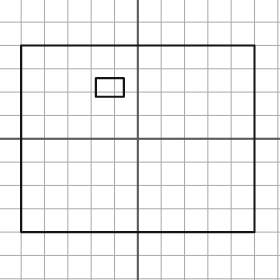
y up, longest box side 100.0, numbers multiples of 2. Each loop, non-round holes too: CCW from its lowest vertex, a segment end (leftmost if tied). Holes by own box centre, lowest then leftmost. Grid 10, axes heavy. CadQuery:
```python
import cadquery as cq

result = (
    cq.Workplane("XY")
    .moveTo(-50.0, -40.0)
    .lineTo(50.0, -40.0)
    .lineTo(50.0, 40.0)
    .lineTo(-50.0, 40.0)
    .close()
    .moveTo(-18.0, 18.0)
    .lineTo(-6.0, 18.0)
    .lineTo(-6.0, 26.0)
    .lineTo(-18.0, 26.0)
    .close()
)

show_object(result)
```